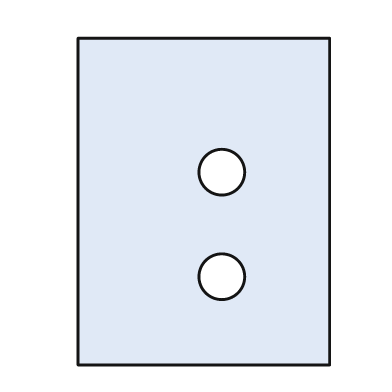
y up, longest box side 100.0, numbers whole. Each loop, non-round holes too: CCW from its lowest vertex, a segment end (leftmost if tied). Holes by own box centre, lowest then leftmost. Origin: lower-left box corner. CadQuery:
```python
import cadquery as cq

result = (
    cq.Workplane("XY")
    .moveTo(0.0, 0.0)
    .lineTo(77.0, 0.0)
    .lineTo(77.0, 100.0)
    .lineTo(0.0, 100.0)
    .close()
    .moveTo(44.0, 27.0)
    .circle(7.0)
    .moveTo(44.0, 59.0)
    .circle(7.0)
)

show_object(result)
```